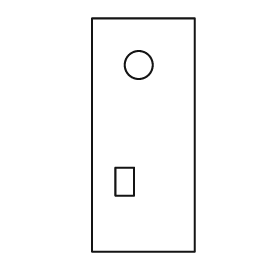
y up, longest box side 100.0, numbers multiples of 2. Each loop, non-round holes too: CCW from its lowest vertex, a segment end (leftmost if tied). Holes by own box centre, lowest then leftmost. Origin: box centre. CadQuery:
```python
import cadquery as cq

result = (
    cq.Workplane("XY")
    .moveTo(-22.0, -50.0)
    .lineTo(22.0, -50.0)
    .lineTo(22.0, 50.0)
    .lineTo(-22.0, 50.0)
    .close()
    .moveTo(-12.0, -26.0)
    .lineTo(-4.0, -26.0)
    .lineTo(-4.0, -14.0)
    .lineTo(-12.0, -14.0)
    .close()
    .moveTo(-2.0, 30.0)
    .circle(6.0)
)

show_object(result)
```